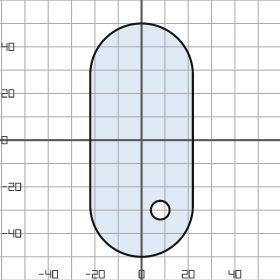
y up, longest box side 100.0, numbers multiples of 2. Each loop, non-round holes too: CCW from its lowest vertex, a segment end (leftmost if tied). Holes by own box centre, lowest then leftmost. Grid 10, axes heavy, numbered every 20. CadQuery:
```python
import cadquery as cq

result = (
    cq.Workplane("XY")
    .moveTo(-22.0, -28.0)
    .threePointArc((0.0, -50.0), (22.0, -28.0))
    .lineTo(22.0, 28.0)
    .threePointArc((0.0, 50.0), (-22.0, 28.0))
    .close()
    .moveTo(8.0, -30.0)
    .circle(4.0)
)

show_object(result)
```